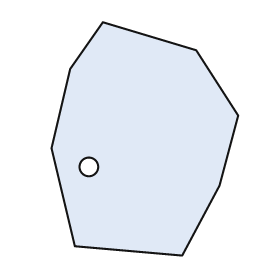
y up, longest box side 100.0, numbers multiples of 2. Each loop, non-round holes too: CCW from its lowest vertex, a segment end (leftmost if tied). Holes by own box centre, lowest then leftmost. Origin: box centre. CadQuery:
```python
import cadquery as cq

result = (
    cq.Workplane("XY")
    .moveTo(16.0, -50.0)
    .lineTo(32.0, -20.0)
    .lineTo(40.0, 10.0)
    .lineTo(22.0, 38.0)
    .lineTo(-18.0, 50.0)
    .lineTo(-32.0, 30.0)
    .lineTo(-40.0, -4.0)
    .lineTo(-30.0, -46.0)
    .close()
    .moveTo(-24.0, -12.0)
    .circle(4.0)
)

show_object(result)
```